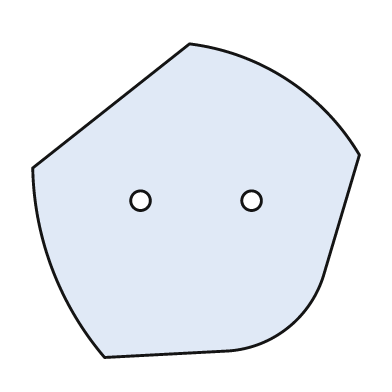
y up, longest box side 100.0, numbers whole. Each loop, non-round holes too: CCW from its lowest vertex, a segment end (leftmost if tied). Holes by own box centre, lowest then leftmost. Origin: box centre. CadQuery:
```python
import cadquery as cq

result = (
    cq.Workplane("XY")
    .moveTo(-28.0, -48.0)
    .lineTo(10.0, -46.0)
    .threePointArc((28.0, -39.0), (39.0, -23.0))
    .lineTo(50.0, 14.0)
    .threePointArc((28.0, 37.0), (-2.0, 48.0))
    .lineTo(-50.0, 10.0)
    .threePointArc((-44.0, -21.0), (-28.0, -48.0))
    .close()
    .moveTo(-17.0, 0.0)
    .circle(3.0)
    .moveTo(17.0, 0.0)
    .circle(3.0)
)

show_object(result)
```